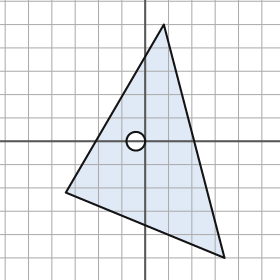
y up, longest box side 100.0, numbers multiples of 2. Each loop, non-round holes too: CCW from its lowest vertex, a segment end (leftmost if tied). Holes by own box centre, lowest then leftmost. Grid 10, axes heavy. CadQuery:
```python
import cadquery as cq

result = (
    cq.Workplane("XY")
    .moveTo(34.0, -50.0)
    .lineTo(8.0, 50.0)
    .lineTo(-34.0, -22.0)
    .close()
    .moveTo(-4.0, 0.0)
    .circle(4.0)
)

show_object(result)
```